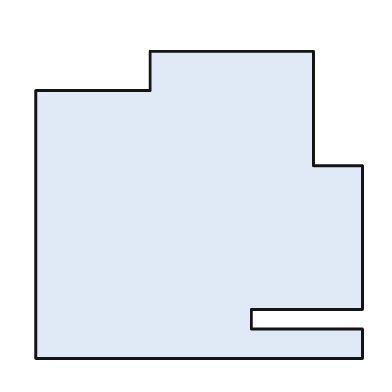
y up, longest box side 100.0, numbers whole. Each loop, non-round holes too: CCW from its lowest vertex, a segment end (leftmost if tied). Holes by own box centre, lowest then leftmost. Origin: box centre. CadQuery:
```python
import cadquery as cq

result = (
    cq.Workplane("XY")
    .moveTo(-50.0, -47.0)
    .lineTo(50.0, -47.0)
    .lineTo(50.0, -38.0)
    .lineTo(16.0, -38.0)
    .lineTo(16.0, -32.0)
    .lineTo(50.0, -32.0)
    .lineTo(50.0, 12.0)
    .lineTo(35.0, 12.0)
    .lineTo(35.0, 47.0)
    .lineTo(-15.0, 47.0)
    .lineTo(-15.0, 35.0)
    .lineTo(-50.0, 35.0)
    .close()
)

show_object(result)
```